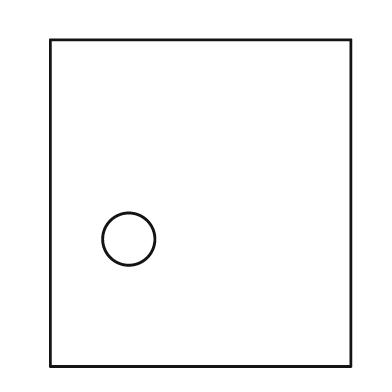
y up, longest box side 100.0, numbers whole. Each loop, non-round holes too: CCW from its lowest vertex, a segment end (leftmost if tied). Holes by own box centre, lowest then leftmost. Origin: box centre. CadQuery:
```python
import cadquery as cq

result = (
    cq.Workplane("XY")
    .moveTo(-46.0, -50.0)
    .lineTo(46.0, -50.0)
    .lineTo(46.0, 50.0)
    .lineTo(-46.0, 50.0)
    .close()
    .moveTo(-22.0, -11.0)
    .circle(8.0)
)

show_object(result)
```